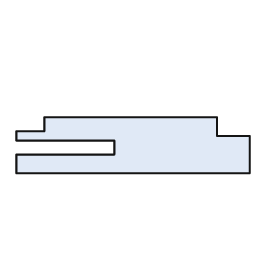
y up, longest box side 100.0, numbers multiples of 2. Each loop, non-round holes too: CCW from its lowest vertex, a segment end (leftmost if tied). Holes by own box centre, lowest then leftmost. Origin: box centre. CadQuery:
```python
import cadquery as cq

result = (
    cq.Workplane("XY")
    .moveTo(-50.0, -12.0)
    .lineTo(50.0, -12.0)
    .lineTo(50.0, 4.0)
    .lineTo(36.0, 4.0)
    .lineTo(36.0, 12.0)
    .lineTo(-38.0, 12.0)
    .lineTo(-38.0, 6.0)
    .lineTo(-50.0, 6.0)
    .lineTo(-50.0, 2.0)
    .lineTo(-8.0, 2.0)
    .lineTo(-8.0, -4.0)
    .lineTo(-50.0, -4.0)
    .close()
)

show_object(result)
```